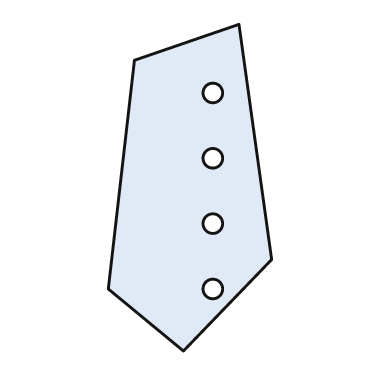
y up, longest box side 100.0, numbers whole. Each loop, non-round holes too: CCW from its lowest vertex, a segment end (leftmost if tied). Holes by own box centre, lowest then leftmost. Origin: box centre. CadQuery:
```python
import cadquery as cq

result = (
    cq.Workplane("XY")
    .moveTo(-2.0, -50.0)
    .lineTo(25.0, -22.0)
    .lineTo(15.0, 50.0)
    .lineTo(-17.0, 39.0)
    .lineTo(-25.0, -31.0)
    .close()
    .moveTo(7.0, -31.0)
    .circle(3.0)
    .moveTo(7.0, -11.0)
    .circle(3.0)
    .moveTo(7.0, 9.0)
    .circle(3.0)
    .moveTo(7.0, 29.0)
    .circle(3.0)
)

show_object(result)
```